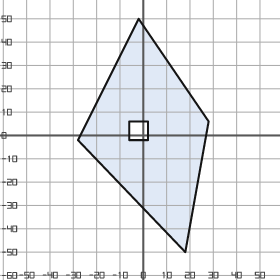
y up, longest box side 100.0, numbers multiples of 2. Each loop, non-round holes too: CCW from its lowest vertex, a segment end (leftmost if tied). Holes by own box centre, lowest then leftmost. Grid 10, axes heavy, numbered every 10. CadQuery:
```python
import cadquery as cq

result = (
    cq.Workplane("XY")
    .moveTo(18.0, -50.0)
    .lineTo(28.0, 6.0)
    .lineTo(-2.0, 50.0)
    .lineTo(-28.0, -2.0)
    .close()
    .moveTo(-6.0, -2.0)
    .lineTo(2.0, -2.0)
    .lineTo(2.0, 6.0)
    .lineTo(-6.0, 6.0)
    .close()
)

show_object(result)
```